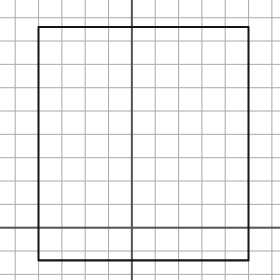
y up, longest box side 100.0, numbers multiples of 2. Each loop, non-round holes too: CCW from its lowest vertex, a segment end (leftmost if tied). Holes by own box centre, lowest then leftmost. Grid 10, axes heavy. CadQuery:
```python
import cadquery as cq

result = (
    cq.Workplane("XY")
    .moveTo(-40.0, -14.0)
    .lineTo(50.0, -14.0)
    .lineTo(50.0, 86.0)
    .lineTo(-40.0, 86.0)
    .close()
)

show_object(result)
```